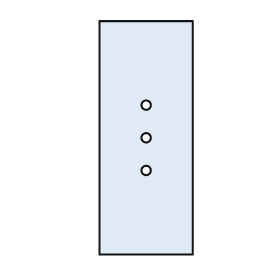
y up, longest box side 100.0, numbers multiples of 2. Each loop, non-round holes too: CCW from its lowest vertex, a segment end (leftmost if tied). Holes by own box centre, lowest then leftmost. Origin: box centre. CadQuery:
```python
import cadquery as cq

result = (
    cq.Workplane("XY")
    .moveTo(-20.0, -50.0)
    .lineTo(20.0, -50.0)
    .lineTo(20.0, 50.0)
    .lineTo(-20.0, 50.0)
    .close()
    .moveTo(0.0, -14.0)
    .circle(2.0)
    .moveTo(0.0, 0.0)
    .circle(2.0)
    .moveTo(0.0, 14.0)
    .circle(2.0)
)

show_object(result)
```